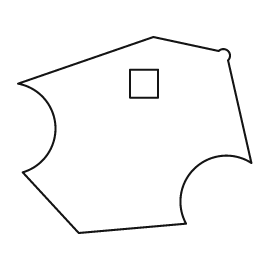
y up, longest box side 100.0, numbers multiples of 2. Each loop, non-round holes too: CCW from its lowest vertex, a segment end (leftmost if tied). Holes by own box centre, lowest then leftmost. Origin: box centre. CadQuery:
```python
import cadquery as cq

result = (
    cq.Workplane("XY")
    .moveTo(-24.0, -42.0)
    .lineTo(22.0, -38.0)
    .threePointArc((26.0, -14.0), (50.0, -12.0))
    .lineTo(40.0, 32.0)
    .threePointArc((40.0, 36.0), (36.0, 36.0))
    .lineTo(8.0, 42.0)
    .lineTo(-50.0, 22.0)
    .threePointArc((-34.0, 4.0), (-48.0, -16.0))
    .close()
    .moveTo(-2.0, 16.0)
    .lineTo(10.0, 16.0)
    .lineTo(10.0, 28.0)
    .lineTo(-2.0, 28.0)
    .close()
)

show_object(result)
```